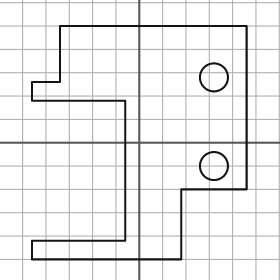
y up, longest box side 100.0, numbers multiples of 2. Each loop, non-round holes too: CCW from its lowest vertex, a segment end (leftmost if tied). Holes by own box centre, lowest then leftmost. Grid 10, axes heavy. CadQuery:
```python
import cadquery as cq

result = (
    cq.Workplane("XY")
    .moveTo(-46.0, -50.0)
    .lineTo(18.0, -50.0)
    .lineTo(18.0, -20.0)
    .lineTo(46.0, -20.0)
    .lineTo(46.0, 50.0)
    .lineTo(-34.0, 50.0)
    .lineTo(-34.0, 26.0)
    .lineTo(-46.0, 26.0)
    .lineTo(-46.0, 18.0)
    .lineTo(-6.0, 18.0)
    .lineTo(-6.0, -42.0)
    .lineTo(-46.0, -42.0)
    .close()
    .moveTo(32.0, -10.0)
    .circle(6.0)
    .moveTo(32.0, 28.0)
    .circle(6.0)
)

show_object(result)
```